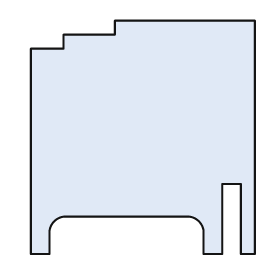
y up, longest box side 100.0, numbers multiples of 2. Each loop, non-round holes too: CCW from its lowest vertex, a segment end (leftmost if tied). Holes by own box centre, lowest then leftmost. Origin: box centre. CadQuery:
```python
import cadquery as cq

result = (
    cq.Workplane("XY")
    .moveTo(-48.0, -50.0)
    .lineTo(-40.0, -50.0)
    .lineTo(-40.0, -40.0)
    .threePointArc((-38.0, -36.0), (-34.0, -34.0))
    .lineTo(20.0, -34.0)
    .threePointArc((24.0, -36.0), (26.0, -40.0))
    .lineTo(26.0, -50.0)
    .lineTo(34.0, -50.0)
    .lineTo(34.0, -20.0)
    .lineTo(42.0, -20.0)
    .lineTo(42.0, -50.0)
    .lineTo(48.0, -50.0)
    .lineTo(48.0, 50.0)
    .lineTo(-12.0, 50.0)
    .lineTo(-12.0, 44.0)
    .lineTo(-34.0, 44.0)
    .lineTo(-34.0, 38.0)
    .lineTo(-48.0, 38.0)
    .close()
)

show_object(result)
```